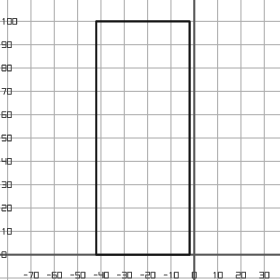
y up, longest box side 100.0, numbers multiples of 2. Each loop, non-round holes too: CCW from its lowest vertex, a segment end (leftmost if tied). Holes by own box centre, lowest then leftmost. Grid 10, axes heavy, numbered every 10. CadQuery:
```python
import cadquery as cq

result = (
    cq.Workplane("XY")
    .moveTo(-42.0, 0.0)
    .lineTo(-2.0, 0.0)
    .lineTo(-2.0, 100.0)
    .lineTo(-42.0, 100.0)
    .close()
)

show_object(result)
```